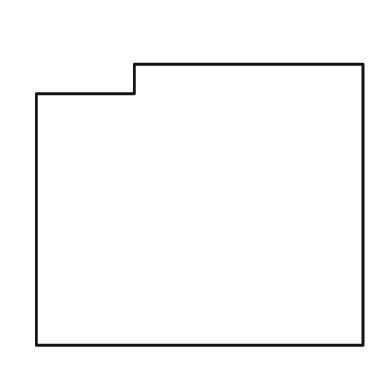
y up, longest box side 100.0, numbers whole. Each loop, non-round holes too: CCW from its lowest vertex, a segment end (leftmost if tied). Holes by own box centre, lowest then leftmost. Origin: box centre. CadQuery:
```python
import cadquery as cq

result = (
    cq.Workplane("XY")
    .moveTo(-50.0, -43.0)
    .lineTo(50.0, -43.0)
    .lineTo(50.0, 43.0)
    .lineTo(-20.0, 43.0)
    .lineTo(-20.0, 34.0)
    .lineTo(-50.0, 34.0)
    .close()
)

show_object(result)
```